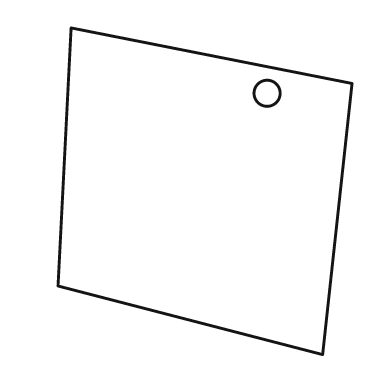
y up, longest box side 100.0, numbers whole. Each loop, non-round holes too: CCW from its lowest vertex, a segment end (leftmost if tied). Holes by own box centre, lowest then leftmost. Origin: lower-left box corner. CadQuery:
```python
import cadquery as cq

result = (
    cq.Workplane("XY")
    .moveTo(81.0, 0.0)
    .lineTo(90.0, 83.0)
    .lineTo(4.0, 100.0)
    .lineTo(0.0, 21.0)
    .close()
    .moveTo(64.0, 80.0)
    .circle(4.0)
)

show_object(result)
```